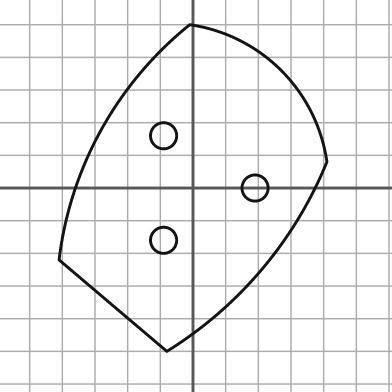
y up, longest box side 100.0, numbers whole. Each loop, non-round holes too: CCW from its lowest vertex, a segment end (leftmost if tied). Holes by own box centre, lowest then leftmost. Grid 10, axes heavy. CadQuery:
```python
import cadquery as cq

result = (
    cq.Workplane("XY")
    .moveTo(-8.0, -50.0)
    .threePointArc((21.0, -25.0), (41.0, 8.0))
    .threePointArc((27.0, 36.0), (-1.0, 50.0))
    .threePointArc((-28.0, 18.0), (-41.0, -22.0))
    .close()
    .moveTo(-9.0, -16.0)
    .circle(4.0)
    .moveTo(19.0, 0.0)
    .circle(4.0)
    .moveTo(-9.0, 16.0)
    .circle(4.0)
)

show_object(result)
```